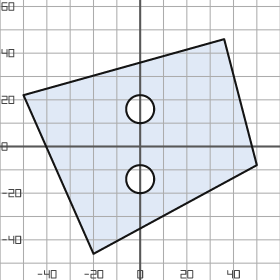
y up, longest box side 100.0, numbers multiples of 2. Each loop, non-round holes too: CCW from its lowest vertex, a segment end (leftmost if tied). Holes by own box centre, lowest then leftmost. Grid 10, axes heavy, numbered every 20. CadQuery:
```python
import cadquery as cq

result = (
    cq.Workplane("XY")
    .moveTo(-20.0, -46.0)
    .lineTo(50.0, -8.0)
    .lineTo(36.0, 46.0)
    .lineTo(-50.0, 22.0)
    .close()
    .moveTo(0.0, -14.0)
    .circle(6.0)
    .moveTo(0.0, 16.0)
    .circle(6.0)
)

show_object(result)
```